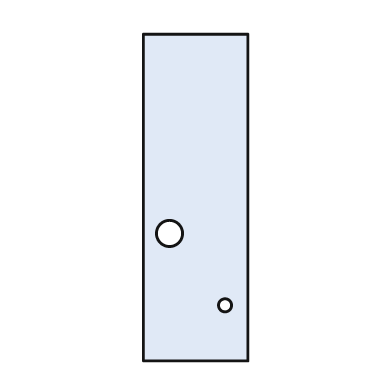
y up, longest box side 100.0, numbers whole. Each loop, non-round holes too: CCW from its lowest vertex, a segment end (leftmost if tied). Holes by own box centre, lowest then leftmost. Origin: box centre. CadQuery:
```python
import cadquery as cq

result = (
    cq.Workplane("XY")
    .moveTo(-16.0, -50.0)
    .lineTo(16.0, -50.0)
    .lineTo(16.0, 50.0)
    .lineTo(-16.0, 50.0)
    .close()
    .moveTo(9.0, -33.0)
    .circle(2.0)
    .moveTo(-8.0, -11.0)
    .circle(4.0)
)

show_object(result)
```